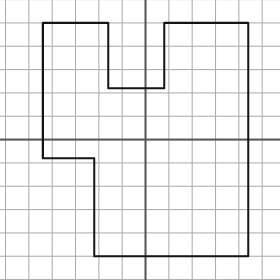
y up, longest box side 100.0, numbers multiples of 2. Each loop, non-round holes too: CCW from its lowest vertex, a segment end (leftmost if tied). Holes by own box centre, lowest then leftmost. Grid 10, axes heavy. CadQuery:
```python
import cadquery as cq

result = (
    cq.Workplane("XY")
    .moveTo(-22.0, -50.0)
    .lineTo(44.0, -50.0)
    .lineTo(44.0, 50.0)
    .lineTo(8.0, 50.0)
    .lineTo(8.0, 22.0)
    .lineTo(-16.0, 22.0)
    .lineTo(-16.0, 50.0)
    .lineTo(-44.0, 50.0)
    .lineTo(-44.0, -8.0)
    .lineTo(-22.0, -8.0)
    .close()
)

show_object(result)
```